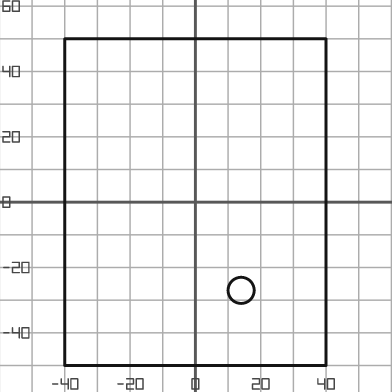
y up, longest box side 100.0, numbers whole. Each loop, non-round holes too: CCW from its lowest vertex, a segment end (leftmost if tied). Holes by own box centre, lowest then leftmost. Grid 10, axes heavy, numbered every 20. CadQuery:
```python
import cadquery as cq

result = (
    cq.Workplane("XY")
    .moveTo(-40.0, -50.0)
    .lineTo(40.0, -50.0)
    .lineTo(40.0, 50.0)
    .lineTo(-40.0, 50.0)
    .close()
    .moveTo(14.0, -27.0)
    .circle(4.0)
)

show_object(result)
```